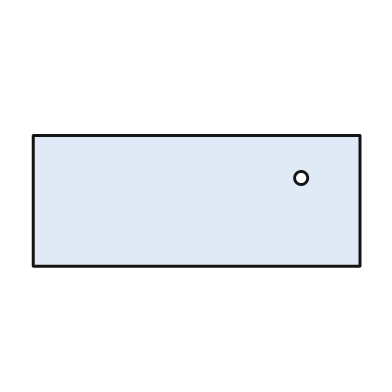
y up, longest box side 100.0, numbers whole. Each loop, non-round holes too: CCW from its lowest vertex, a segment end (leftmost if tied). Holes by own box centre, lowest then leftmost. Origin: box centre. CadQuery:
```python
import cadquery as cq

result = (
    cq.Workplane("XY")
    .moveTo(-50.0, -20.0)
    .lineTo(50.0, -20.0)
    .lineTo(50.0, 20.0)
    .lineTo(-50.0, 20.0)
    .close()
    .moveTo(32.0, 7.0)
    .circle(2.0)
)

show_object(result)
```